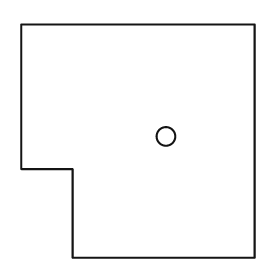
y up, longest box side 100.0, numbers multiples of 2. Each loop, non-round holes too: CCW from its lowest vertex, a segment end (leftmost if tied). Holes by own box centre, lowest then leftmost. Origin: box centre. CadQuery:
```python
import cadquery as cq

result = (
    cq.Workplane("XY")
    .moveTo(-28.0, -50.0)
    .lineTo(50.0, -50.0)
    .lineTo(50.0, 50.0)
    .lineTo(-50.0, 50.0)
    .lineTo(-50.0, -12.0)
    .lineTo(-28.0, -12.0)
    .close()
    .moveTo(12.0, 2.0)
    .circle(4.0)
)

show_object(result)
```